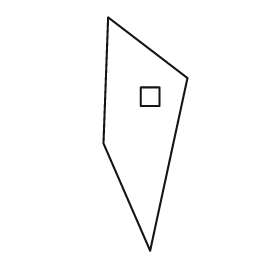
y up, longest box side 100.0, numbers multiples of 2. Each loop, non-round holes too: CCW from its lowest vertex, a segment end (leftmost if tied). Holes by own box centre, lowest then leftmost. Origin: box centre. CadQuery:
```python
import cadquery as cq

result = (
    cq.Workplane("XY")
    .moveTo(2.0, -50.0)
    .lineTo(18.0, 24.0)
    .lineTo(-16.0, 50.0)
    .lineTo(-18.0, -4.0)
    .close()
    .moveTo(-2.0, 12.0)
    .lineTo(6.0, 12.0)
    .lineTo(6.0, 20.0)
    .lineTo(-2.0, 20.0)
    .close()
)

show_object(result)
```